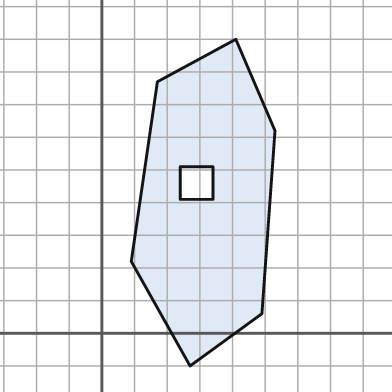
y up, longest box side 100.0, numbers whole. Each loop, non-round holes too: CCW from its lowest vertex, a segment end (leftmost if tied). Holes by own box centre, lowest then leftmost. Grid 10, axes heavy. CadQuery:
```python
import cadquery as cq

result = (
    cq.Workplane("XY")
    .moveTo(27.0, -10.0)
    .lineTo(49.0, 6.0)
    .lineTo(53.0, 62.0)
    .lineTo(41.0, 90.0)
    .lineTo(17.0, 77.0)
    .lineTo(9.0, 22.0)
    .close()
    .moveTo(24.0, 41.0)
    .lineTo(34.0, 41.0)
    .lineTo(34.0, 51.0)
    .lineTo(24.0, 51.0)
    .close()
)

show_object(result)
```